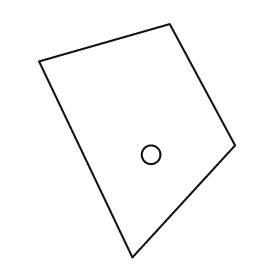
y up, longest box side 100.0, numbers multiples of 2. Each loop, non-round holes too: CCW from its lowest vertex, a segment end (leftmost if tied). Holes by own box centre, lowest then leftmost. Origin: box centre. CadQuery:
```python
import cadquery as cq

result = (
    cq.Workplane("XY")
    .moveTo(-2.0, -50.0)
    .lineTo(42.0, -2.0)
    .lineTo(14.0, 50.0)
    .lineTo(-42.0, 34.0)
    .close()
    .moveTo(6.0, -6.0)
    .circle(4.0)
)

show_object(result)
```